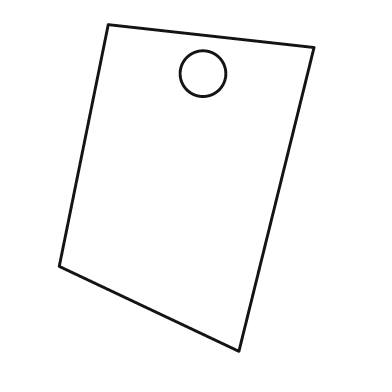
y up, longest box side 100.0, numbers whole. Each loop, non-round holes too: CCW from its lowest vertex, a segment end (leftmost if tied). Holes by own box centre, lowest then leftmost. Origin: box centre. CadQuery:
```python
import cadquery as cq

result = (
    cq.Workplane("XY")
    .moveTo(16.0, -50.0)
    .lineTo(39.0, 43.0)
    .lineTo(-24.0, 50.0)
    .lineTo(-39.0, -24.0)
    .close()
    .moveTo(5.0, 35.0)
    .circle(7.0)
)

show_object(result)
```